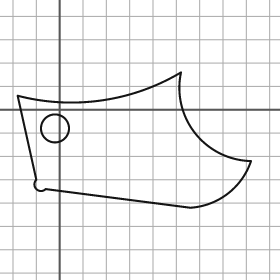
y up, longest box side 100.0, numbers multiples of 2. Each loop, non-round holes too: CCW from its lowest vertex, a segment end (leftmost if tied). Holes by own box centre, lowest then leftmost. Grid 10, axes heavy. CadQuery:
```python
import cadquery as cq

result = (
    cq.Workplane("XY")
    .moveTo(56.0, -42.0)
    .threePointArc((72.0, -36.0), (82.0, -22.0))
    .threePointArc((58.0, -10.0), (52.0, 16.0))
    .threePointArc((18.0, 4.0), (-18.0, 6.0))
    .lineTo(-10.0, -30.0)
    .threePointArc((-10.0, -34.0), (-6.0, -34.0))
    .close()
    .moveTo(-2.0, -8.0)
    .circle(6.0)
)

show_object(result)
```